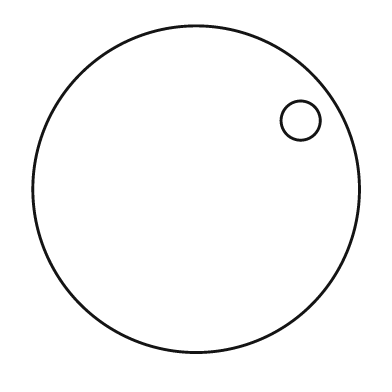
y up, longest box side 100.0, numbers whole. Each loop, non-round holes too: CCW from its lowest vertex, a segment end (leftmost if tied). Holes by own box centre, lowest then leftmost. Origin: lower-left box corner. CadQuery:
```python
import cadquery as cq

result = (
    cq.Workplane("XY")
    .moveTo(50.0, 50.0)
    .circle(50.0)
    .moveTo(82.0, 71.0)
    .circle(6.0)
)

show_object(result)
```